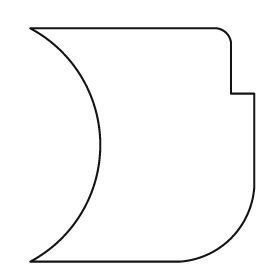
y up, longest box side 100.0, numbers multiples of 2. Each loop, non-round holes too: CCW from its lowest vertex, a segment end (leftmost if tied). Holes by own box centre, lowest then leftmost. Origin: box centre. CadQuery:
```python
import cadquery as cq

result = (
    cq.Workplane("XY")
    .moveTo(-48.0, -50.0)
    .lineTo(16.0, -50.0)
    .threePointArc((38.0, -40.0), (48.0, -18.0))
    .lineTo(48.0, 22.0)
    .lineTo(38.0, 22.0)
    .lineTo(38.0, 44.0)
    .threePointArc((36.0, 48.0), (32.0, 50.0))
    .lineTo(-48.0, 50.0)
    .threePointArc((-18.0, 0.0), (-48.0, -50.0))
    .close()
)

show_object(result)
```